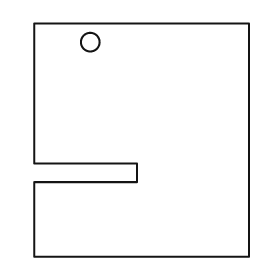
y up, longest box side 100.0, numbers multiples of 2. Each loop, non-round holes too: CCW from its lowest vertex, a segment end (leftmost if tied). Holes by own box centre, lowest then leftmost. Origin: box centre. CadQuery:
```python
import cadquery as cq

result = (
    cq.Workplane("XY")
    .moveTo(-46.0, -50.0)
    .lineTo(46.0, -50.0)
    .lineTo(46.0, 50.0)
    .lineTo(-46.0, 50.0)
    .lineTo(-46.0, -10.0)
    .lineTo(-2.0, -10.0)
    .lineTo(-2.0, -18.0)
    .lineTo(-46.0, -18.0)
    .close()
    .moveTo(-22.0, 42.0)
    .circle(4.0)
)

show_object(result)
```